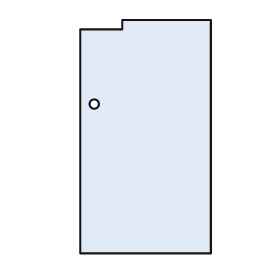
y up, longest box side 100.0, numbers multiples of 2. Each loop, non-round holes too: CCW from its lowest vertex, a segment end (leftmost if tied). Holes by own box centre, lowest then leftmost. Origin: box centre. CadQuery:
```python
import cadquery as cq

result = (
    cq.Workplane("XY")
    .moveTo(-28.0, -50.0)
    .lineTo(28.0, -50.0)
    .lineTo(28.0, 50.0)
    .lineTo(-10.0, 50.0)
    .lineTo(-10.0, 46.0)
    .lineTo(-28.0, 46.0)
    .close()
    .moveTo(-22.0, 14.0)
    .circle(2.0)
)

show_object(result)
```